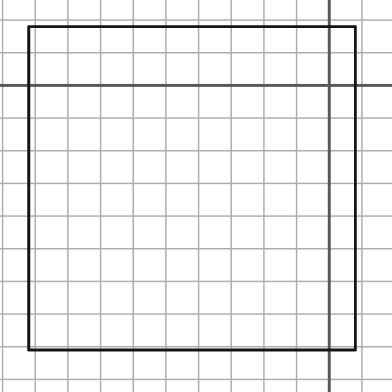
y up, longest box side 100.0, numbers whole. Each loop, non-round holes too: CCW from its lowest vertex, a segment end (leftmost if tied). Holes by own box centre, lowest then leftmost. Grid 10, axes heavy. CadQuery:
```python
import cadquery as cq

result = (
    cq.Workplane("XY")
    .moveTo(-92.0, -81.0)
    .lineTo(8.0, -81.0)
    .lineTo(8.0, 18.0)
    .lineTo(-92.0, 18.0)
    .close()
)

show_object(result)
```